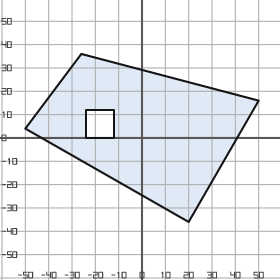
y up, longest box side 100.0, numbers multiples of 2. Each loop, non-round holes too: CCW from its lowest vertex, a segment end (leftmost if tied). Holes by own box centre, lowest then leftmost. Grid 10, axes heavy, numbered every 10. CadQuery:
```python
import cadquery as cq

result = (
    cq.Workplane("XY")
    .moveTo(20.0, -36.0)
    .lineTo(50.0, 16.0)
    .lineTo(-26.0, 36.0)
    .lineTo(-50.0, 4.0)
    .close()
    .moveTo(-24.0, 0.0)
    .lineTo(-12.0, 0.0)
    .lineTo(-12.0, 12.0)
    .lineTo(-24.0, 12.0)
    .close()
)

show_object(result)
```